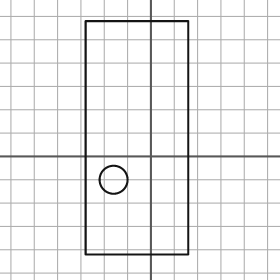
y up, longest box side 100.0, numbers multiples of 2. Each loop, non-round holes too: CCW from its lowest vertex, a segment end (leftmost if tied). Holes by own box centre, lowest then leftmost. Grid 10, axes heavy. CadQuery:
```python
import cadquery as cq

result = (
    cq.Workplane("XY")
    .moveTo(-28.0, -42.0)
    .lineTo(16.0, -42.0)
    .lineTo(16.0, 58.0)
    .lineTo(-28.0, 58.0)
    .close()
    .moveTo(-16.0, -10.0)
    .circle(6.0)
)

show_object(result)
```